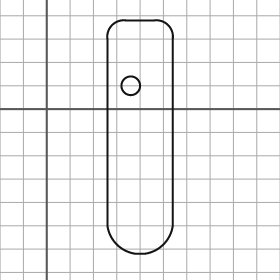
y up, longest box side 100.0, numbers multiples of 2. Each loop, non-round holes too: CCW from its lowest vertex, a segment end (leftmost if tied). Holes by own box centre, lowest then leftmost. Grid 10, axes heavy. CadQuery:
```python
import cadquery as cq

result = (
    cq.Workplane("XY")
    .moveTo(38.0, -62.0)
    .lineTo(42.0, -62.0)
    .threePointArc((50.0, -58.0), (54.0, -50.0))
    .lineTo(54.0, 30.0)
    .threePointArc((52.0, 36.0), (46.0, 38.0))
    .lineTo(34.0, 38.0)
    .threePointArc((28.0, 36.0), (26.0, 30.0))
    .lineTo(26.0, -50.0)
    .threePointArc((30.0, -58.0), (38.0, -62.0))
    .close()
    .moveTo(36.0, 10.0)
    .circle(4.0)
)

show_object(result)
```